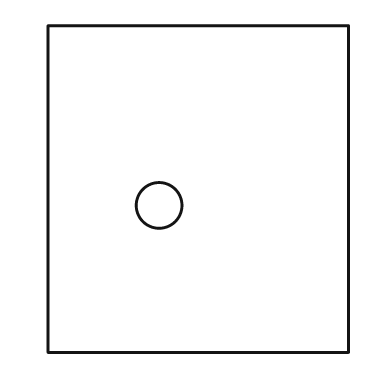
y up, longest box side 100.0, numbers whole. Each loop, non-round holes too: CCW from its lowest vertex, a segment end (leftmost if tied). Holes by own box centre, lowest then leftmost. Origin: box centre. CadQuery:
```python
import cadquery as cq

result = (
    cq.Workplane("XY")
    .moveTo(-46.0, -50.0)
    .lineTo(46.0, -50.0)
    .lineTo(46.0, 50.0)
    .lineTo(-46.0, 50.0)
    .close()
    .moveTo(-12.0, -5.0)
    .circle(7.0)
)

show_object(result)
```